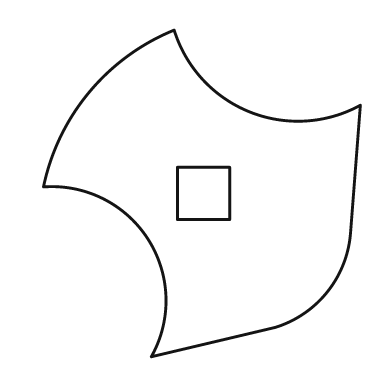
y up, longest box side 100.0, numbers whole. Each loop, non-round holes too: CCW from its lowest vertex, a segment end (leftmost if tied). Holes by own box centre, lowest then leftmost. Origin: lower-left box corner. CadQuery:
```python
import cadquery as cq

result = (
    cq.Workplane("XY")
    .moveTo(33.0, 0.0)
    .lineTo(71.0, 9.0)
    .threePointArc((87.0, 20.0), (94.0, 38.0))
    .lineTo(97.0, 77.0)
    .threePointArc((63.0, 75.0), (40.0, 100.0))
    .threePointArc((14.0, 81.0), (0.0, 52.0))
    .threePointArc((32.0, 36.0), (33.0, 0.0))
    .close()
    .moveTo(41.0, 42.0)
    .lineTo(57.0, 42.0)
    .lineTo(57.0, 58.0)
    .lineTo(41.0, 58.0)
    .close()
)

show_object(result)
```